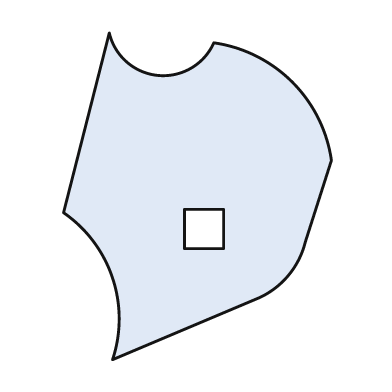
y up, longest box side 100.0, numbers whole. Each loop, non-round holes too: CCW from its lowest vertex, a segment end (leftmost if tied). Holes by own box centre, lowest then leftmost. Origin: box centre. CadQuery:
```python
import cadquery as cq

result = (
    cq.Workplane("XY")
    .moveTo(-26.0, -50.0)
    .lineTo(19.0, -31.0)
    .threePointArc((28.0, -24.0), (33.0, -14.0))
    .lineTo(41.0, 11.0)
    .threePointArc((29.0, 35.0), (5.0, 47.0))
    .threePointArc((-12.0, 37.0), (-27.0, 50.0))
    .lineTo(-41.0, -5.0)
    .threePointArc((-26.0, -25.0), (-26.0, -50.0))
    .close()
    .moveTo(-4.0, -16.0)
    .lineTo(8.0, -16.0)
    .lineTo(8.0, -4.0)
    .lineTo(-4.0, -4.0)
    .close()
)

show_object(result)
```